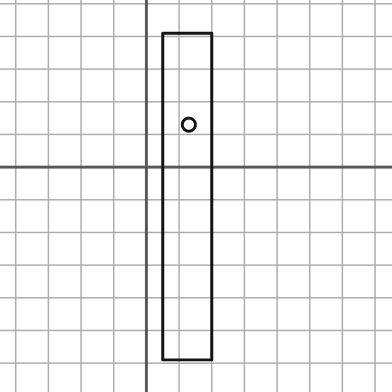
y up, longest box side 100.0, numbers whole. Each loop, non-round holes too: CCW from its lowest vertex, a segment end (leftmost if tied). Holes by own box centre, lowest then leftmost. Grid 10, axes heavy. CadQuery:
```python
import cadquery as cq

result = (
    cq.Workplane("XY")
    .moveTo(5.0, -59.0)
    .lineTo(20.0, -59.0)
    .lineTo(20.0, 41.0)
    .lineTo(5.0, 41.0)
    .close()
    .moveTo(13.0, 13.0)
    .circle(2.0)
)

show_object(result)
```